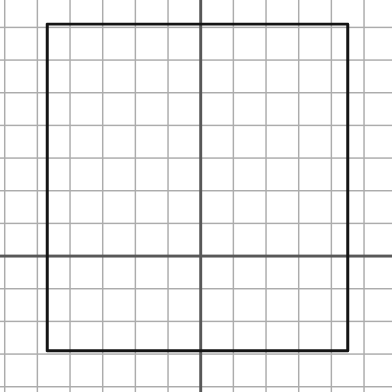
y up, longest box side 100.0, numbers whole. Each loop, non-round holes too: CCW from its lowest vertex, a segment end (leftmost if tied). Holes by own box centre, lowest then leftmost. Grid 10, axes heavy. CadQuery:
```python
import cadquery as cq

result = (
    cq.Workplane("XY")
    .moveTo(-47.0, -29.0)
    .lineTo(45.0, -29.0)
    .lineTo(45.0, 71.0)
    .lineTo(-47.0, 71.0)
    .close()
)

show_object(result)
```